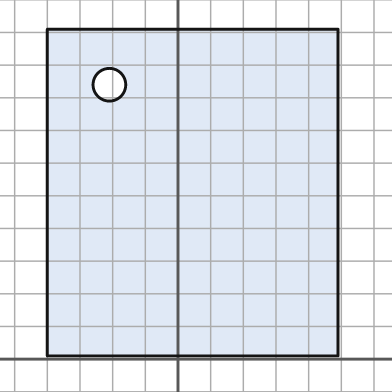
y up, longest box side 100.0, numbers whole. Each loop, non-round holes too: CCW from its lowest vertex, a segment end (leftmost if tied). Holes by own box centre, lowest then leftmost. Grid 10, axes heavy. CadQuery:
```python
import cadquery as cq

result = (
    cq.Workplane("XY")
    .moveTo(-40.0, 1.0)
    .lineTo(49.0, 1.0)
    .lineTo(49.0, 101.0)
    .lineTo(-40.0, 101.0)
    .close()
    .moveTo(-21.0, 84.0)
    .circle(5.0)
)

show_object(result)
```